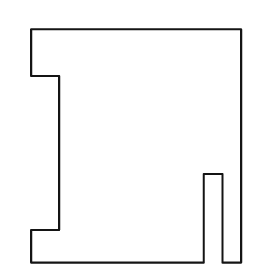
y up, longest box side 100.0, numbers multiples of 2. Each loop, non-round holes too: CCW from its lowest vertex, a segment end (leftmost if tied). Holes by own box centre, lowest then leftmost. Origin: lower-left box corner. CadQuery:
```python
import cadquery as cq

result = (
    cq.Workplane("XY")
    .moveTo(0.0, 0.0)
    .lineTo(74.0, 0.0)
    .lineTo(74.0, 38.0)
    .lineTo(82.0, 38.0)
    .lineTo(82.0, 0.0)
    .lineTo(90.0, 0.0)
    .lineTo(90.0, 100.0)
    .lineTo(0.0, 100.0)
    .lineTo(0.0, 80.0)
    .lineTo(12.0, 80.0)
    .lineTo(12.0, 14.0)
    .lineTo(0.0, 14.0)
    .close()
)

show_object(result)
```